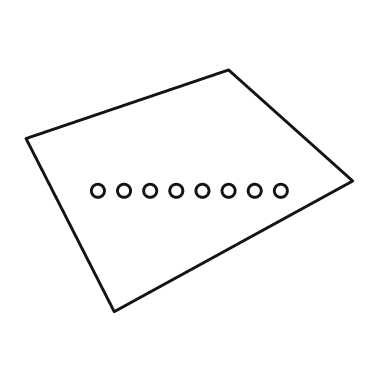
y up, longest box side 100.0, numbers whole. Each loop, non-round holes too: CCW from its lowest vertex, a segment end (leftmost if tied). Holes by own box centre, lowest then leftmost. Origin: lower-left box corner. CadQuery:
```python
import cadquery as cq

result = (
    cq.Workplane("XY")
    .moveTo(27.0, 0.0)
    .lineTo(100.0, 40.0)
    .lineTo(62.0, 74.0)
    .lineTo(0.0, 53.0)
    .close()
    .moveTo(22.0, 37.0)
    .circle(2.0)
    .moveTo(30.0, 37.0)
    .circle(2.0)
    .moveTo(38.0, 37.0)
    .circle(2.0)
    .moveTo(46.0, 37.0)
    .circle(2.0)
    .moveTo(54.0, 37.0)
    .circle(2.0)
    .moveTo(62.0, 37.0)
    .circle(2.0)
    .moveTo(70.0, 37.0)
    .circle(2.0)
    .moveTo(78.0, 37.0)
    .circle(2.0)
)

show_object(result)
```